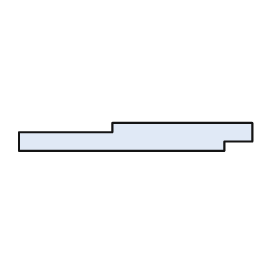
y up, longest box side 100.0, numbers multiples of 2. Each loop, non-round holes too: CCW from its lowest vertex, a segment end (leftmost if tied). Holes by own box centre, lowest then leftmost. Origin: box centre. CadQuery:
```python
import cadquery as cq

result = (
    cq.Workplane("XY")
    .moveTo(-50.0, -6.0)
    .lineTo(38.0, -6.0)
    .lineTo(38.0, -2.0)
    .lineTo(50.0, -2.0)
    .lineTo(50.0, 6.0)
    .lineTo(-10.0, 6.0)
    .lineTo(-10.0, 2.0)
    .lineTo(-50.0, 2.0)
    .close()
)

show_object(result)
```